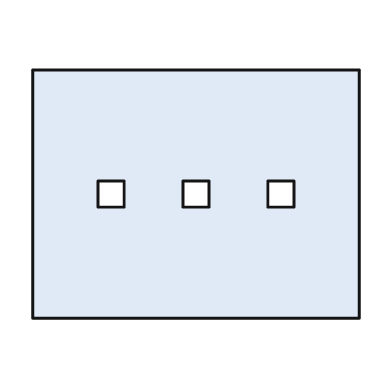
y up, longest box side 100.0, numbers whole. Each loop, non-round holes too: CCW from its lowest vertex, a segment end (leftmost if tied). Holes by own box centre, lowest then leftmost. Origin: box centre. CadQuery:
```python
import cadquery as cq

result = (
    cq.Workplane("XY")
    .moveTo(-50.0, -38.0)
    .lineTo(50.0, -38.0)
    .lineTo(50.0, 38.0)
    .lineTo(-50.0, 38.0)
    .close()
    .moveTo(-30.0, -4.0)
    .lineTo(-22.0, -4.0)
    .lineTo(-22.0, 4.0)
    .lineTo(-30.0, 4.0)
    .close()
    .moveTo(-4.0, -4.0)
    .lineTo(4.0, -4.0)
    .lineTo(4.0, 4.0)
    .lineTo(-4.0, 4.0)
    .close()
    .moveTo(22.0, -4.0)
    .lineTo(30.0, -4.0)
    .lineTo(30.0, 4.0)
    .lineTo(22.0, 4.0)
    .close()
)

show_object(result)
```